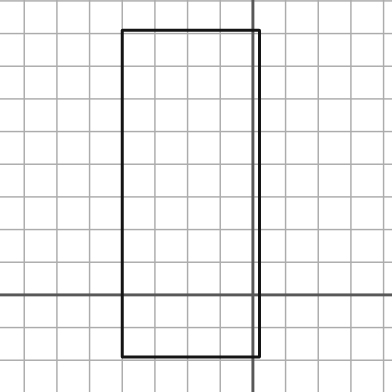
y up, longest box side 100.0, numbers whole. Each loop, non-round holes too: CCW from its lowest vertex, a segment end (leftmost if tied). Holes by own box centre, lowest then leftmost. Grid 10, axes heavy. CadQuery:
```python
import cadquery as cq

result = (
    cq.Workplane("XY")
    .moveTo(-40.0, -19.0)
    .lineTo(2.0, -19.0)
    .lineTo(2.0, 81.0)
    .lineTo(-40.0, 81.0)
    .close()
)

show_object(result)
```